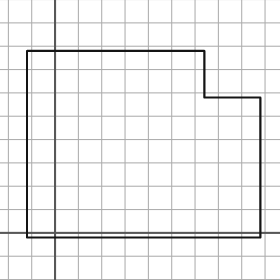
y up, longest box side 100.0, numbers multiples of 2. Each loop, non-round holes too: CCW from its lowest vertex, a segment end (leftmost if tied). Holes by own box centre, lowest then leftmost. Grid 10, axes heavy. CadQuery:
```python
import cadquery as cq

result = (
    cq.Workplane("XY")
    .moveTo(-12.0, -2.0)
    .lineTo(88.0, -2.0)
    .lineTo(88.0, 58.0)
    .lineTo(64.0, 58.0)
    .lineTo(64.0, 78.0)
    .lineTo(-12.0, 78.0)
    .close()
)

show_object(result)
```